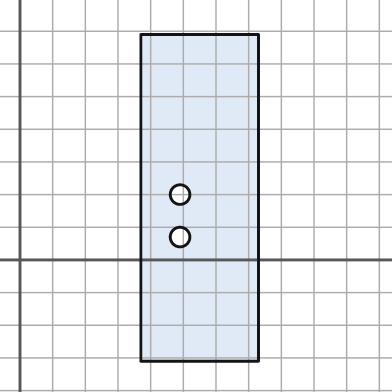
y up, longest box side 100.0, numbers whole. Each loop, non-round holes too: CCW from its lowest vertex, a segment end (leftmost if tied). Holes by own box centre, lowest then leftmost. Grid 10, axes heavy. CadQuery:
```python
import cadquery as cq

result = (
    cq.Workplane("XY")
    .moveTo(37.0, -31.0)
    .lineTo(73.0, -31.0)
    .lineTo(73.0, 69.0)
    .lineTo(37.0, 69.0)
    .close()
    .moveTo(49.0, 7.0)
    .circle(3.0)
    .moveTo(49.0, 20.0)
    .circle(3.0)
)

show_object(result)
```